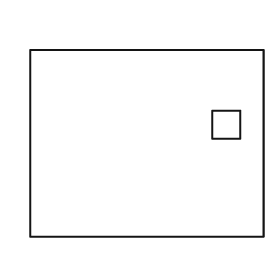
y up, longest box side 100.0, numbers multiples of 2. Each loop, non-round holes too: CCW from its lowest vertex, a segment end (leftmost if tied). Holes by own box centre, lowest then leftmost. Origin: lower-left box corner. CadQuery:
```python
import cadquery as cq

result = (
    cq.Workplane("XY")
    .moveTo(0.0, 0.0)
    .lineTo(100.0, 0.0)
    .lineTo(100.0, 80.0)
    .lineTo(0.0, 80.0)
    .close()
    .moveTo(78.0, 42.0)
    .lineTo(90.0, 42.0)
    .lineTo(90.0, 54.0)
    .lineTo(78.0, 54.0)
    .close()
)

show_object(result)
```